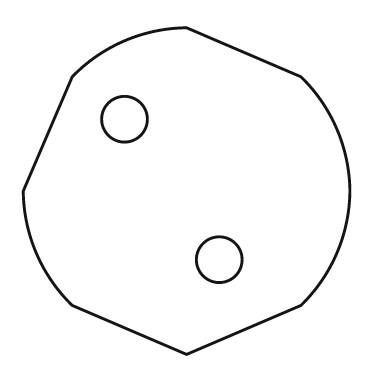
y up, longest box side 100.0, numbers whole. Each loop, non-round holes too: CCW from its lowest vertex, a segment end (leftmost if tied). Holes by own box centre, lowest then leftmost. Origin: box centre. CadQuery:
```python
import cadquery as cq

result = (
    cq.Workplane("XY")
    .moveTo(0.0, -50.0)
    .lineTo(35.0, -35.0)
    .threePointArc((46.0, -19.0), (50.0, 0.0))
    .threePointArc((46.0, 19.0), (35.0, 35.0))
    .lineTo(0.0, 50.0)
    .threePointArc((-19.0, 46.0), (-35.0, 35.0))
    .lineTo(-50.0, 0.0)
    .threePointArc((-46.0, -19.0), (-35.0, -35.0))
    .close()
    .moveTo(10.0, -21.0)
    .circle(7.0)
    .moveTo(-19.0, 22.0)
    .circle(7.0)
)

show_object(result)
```